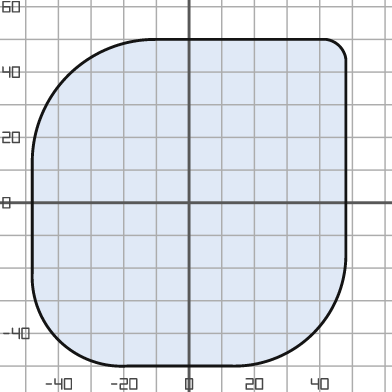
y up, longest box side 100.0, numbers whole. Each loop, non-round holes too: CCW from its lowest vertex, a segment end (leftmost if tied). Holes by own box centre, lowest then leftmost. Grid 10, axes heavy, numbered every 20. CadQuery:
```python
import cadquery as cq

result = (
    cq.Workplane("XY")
    .moveTo(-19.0, -50.0)
    .lineTo(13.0, -50.0)
    .threePointArc((38.0, -40.0), (48.0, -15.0))
    .lineTo(48.0, 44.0)
    .threePointArc((46.0, 48.0), (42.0, 50.0))
    .lineTo(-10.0, 50.0)
    .threePointArc((-37.0, 39.0), (-48.0, 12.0))
    .lineTo(-48.0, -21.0)
    .threePointArc((-40.0, -42.0), (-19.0, -50.0))
    .close()
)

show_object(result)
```